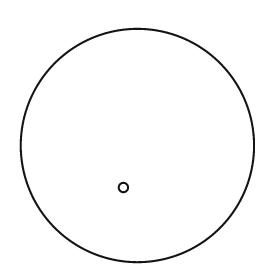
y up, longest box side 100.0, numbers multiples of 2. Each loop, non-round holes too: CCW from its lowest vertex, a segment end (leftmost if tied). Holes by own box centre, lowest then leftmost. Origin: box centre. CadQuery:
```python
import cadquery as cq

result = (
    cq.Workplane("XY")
    .moveTo(0.0, 0.0)
    .circle(50.0)
    .moveTo(-6.0, -18.0)
    .circle(2.0)
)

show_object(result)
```